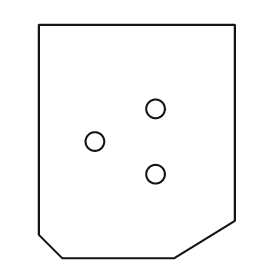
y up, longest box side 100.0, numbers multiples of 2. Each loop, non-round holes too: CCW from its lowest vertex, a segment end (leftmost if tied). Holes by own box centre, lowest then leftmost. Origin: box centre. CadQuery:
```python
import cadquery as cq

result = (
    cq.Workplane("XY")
    .moveTo(-32.0, -50.0)
    .lineTo(16.0, -50.0)
    .lineTo(42.0, -34.0)
    .lineTo(42.0, 50.0)
    .lineTo(-42.0, 50.0)
    .lineTo(-42.0, -40.0)
    .close()
    .moveTo(8.0, -14.0)
    .circle(4.0)
    .moveTo(-18.0, 0.0)
    .circle(4.0)
    .moveTo(8.0, 14.0)
    .circle(4.0)
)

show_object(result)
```